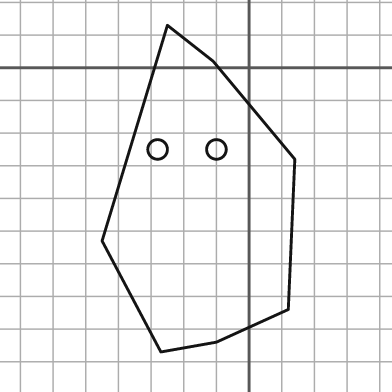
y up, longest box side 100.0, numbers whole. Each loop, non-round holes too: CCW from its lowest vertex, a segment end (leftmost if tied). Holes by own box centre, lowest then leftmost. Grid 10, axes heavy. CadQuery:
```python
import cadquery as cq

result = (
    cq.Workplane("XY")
    .moveTo(-27.0, -87.0)
    .lineTo(-10.0, -84.0)
    .lineTo(12.0, -74.0)
    .lineTo(14.0, -28.0)
    .lineTo(-11.0, 2.0)
    .lineTo(-25.0, 13.0)
    .lineTo(-45.0, -53.0)
    .close()
    .moveTo(-28.0, -25.0)
    .circle(3.0)
    .moveTo(-10.0, -25.0)
    .circle(3.0)
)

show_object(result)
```